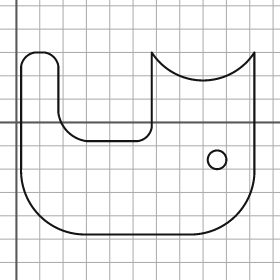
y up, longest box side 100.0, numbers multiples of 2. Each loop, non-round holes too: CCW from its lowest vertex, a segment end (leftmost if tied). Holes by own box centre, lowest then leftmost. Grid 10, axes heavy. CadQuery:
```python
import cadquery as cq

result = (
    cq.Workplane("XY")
    .moveTo(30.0, -48.0)
    .lineTo(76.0, -48.0)
    .threePointArc((94.0, -40.0), (102.0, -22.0))
    .lineTo(102.0, 30.0)
    .threePointArc((80.0, 18.0), (58.0, 30.0))
    .lineTo(58.0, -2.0)
    .threePointArc((56.0, -6.0), (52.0, -8.0))
    .lineTo(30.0, -8.0)
    .threePointArc((22.0, -4.0), (18.0, 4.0))
    .lineTo(18.0, 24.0)
    .threePointArc((16.0, 28.0), (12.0, 30.0))
    .lineTo(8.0, 30.0)
    .threePointArc((4.0, 28.0), (2.0, 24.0))
    .lineTo(2.0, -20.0)
    .threePointArc((10.0, -40.0), (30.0, -48.0))
    .close()
    .moveTo(86.0, -16.0)
    .circle(4.0)
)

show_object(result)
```